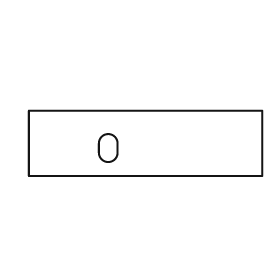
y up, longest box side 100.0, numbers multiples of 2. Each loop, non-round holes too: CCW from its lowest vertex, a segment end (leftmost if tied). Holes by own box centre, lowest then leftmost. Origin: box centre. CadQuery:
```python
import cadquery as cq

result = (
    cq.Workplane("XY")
    .moveTo(-50.0, -14.0)
    .lineTo(50.0, -14.0)
    .lineTo(50.0, 14.0)
    .lineTo(-50.0, 14.0)
    .close()
    .moveTo(-20.0, -4.0)
    .threePointArc((-16.0, -8.0), (-12.0, -4.0))
    .lineTo(-12.0, 0.0)
    .threePointArc((-16.0, 4.0), (-20.0, 0.0))
    .close()
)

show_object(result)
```